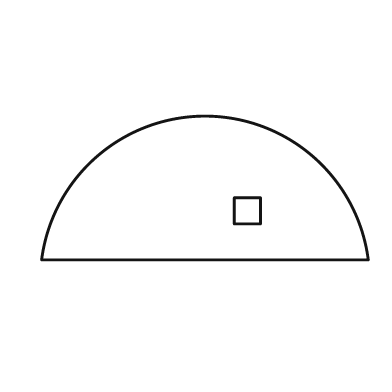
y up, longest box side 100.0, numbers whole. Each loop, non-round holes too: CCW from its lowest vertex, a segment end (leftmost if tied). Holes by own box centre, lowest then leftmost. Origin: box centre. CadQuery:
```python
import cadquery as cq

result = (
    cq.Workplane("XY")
    .moveTo(-50.0, -22.0)
    .lineTo(50.0, -22.0)
    .threePointArc((0.0, 22.0), (-50.0, -22.0))
    .close()
    .moveTo(9.0, -11.0)
    .lineTo(17.0, -11.0)
    .lineTo(17.0, -3.0)
    .lineTo(9.0, -3.0)
    .close()
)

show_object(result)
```